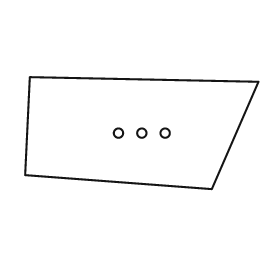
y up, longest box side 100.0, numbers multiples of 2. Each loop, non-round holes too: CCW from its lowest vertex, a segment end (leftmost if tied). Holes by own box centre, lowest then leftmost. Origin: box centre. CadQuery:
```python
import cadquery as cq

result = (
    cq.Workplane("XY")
    .moveTo(30.0, -24.0)
    .lineTo(50.0, 22.0)
    .lineTo(-48.0, 24.0)
    .lineTo(-50.0, -18.0)
    .close()
    .moveTo(-10.0, 0.0)
    .circle(2.0)
    .moveTo(0.0, 0.0)
    .circle(2.0)
    .moveTo(10.0, 0.0)
    .circle(2.0)
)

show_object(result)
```